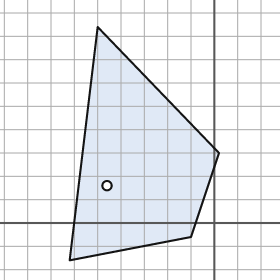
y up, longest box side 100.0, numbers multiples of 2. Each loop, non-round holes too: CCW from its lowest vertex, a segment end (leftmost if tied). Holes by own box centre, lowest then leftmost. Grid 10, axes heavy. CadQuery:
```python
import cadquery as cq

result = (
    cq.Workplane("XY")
    .moveTo(-62.0, -16.0)
    .lineTo(-10.0, -6.0)
    .lineTo(2.0, 30.0)
    .lineTo(-50.0, 84.0)
    .close()
    .moveTo(-46.0, 16.0)
    .circle(2.0)
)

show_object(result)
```